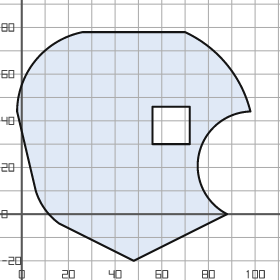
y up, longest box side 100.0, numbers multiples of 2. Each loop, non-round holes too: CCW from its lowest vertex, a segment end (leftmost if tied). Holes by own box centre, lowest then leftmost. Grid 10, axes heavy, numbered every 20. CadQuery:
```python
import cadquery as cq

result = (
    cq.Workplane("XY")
    .moveTo(48.0, -20.0)
    .lineTo(88.0, 0.0)
    .threePointArc((76.0, 26.0), (98.0, 44.0))
    .threePointArc((88.0, 64.0), (70.0, 78.0))
    .lineTo(26.0, 78.0)
    .threePointArc((6.0, 66.0), (-2.0, 44.0))
    .lineTo(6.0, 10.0)
    .threePointArc((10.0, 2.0), (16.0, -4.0))
    .close()
    .moveTo(56.0, 30.0)
    .lineTo(72.0, 30.0)
    .lineTo(72.0, 46.0)
    .lineTo(56.0, 46.0)
    .close()
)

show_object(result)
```